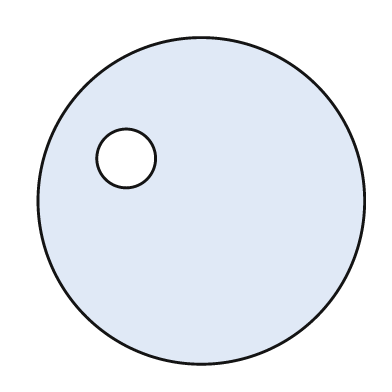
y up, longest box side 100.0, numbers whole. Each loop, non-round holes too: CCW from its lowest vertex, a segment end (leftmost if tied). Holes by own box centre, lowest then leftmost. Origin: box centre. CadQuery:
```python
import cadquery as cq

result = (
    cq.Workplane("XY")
    .moveTo(0.0, 0.0)
    .circle(50.0)
    .moveTo(-23.0, 13.0)
    .circle(9.0)
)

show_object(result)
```